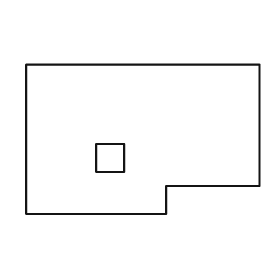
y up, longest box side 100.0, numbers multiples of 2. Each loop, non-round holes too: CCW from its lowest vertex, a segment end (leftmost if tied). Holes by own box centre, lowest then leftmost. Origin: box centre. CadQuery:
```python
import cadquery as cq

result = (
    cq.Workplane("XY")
    .moveTo(-50.0, -32.0)
    .lineTo(10.0, -32.0)
    .lineTo(10.0, -20.0)
    .lineTo(50.0, -20.0)
    .lineTo(50.0, 32.0)
    .lineTo(-50.0, 32.0)
    .close()
    .moveTo(-20.0, -14.0)
    .lineTo(-8.0, -14.0)
    .lineTo(-8.0, -2.0)
    .lineTo(-20.0, -2.0)
    .close()
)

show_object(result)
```